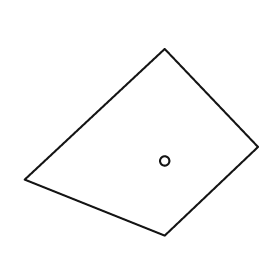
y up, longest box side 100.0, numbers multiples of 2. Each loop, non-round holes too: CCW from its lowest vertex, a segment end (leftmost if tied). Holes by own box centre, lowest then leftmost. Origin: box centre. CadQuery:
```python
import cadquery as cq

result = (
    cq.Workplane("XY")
    .moveTo(10.0, -40.0)
    .lineTo(50.0, -2.0)
    .lineTo(10.0, 40.0)
    .lineTo(-50.0, -16.0)
    .close()
    .moveTo(10.0, -8.0)
    .circle(2.0)
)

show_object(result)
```